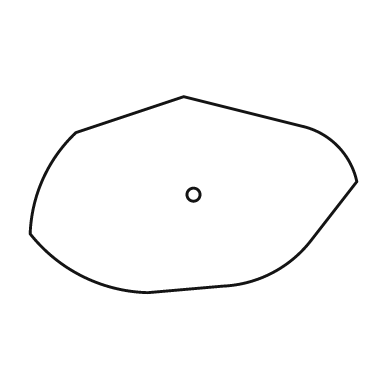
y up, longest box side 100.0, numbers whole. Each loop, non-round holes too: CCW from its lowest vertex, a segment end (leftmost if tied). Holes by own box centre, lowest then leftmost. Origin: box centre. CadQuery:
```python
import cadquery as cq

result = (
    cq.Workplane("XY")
    .moveTo(-14.0, -30.0)
    .lineTo(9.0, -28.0)
    .threePointArc((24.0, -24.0), (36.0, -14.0))
    .lineTo(50.0, 4.0)
    .threePointArc((44.0, 15.0), (33.0, 21.0))
    .lineTo(-3.0, 30.0)
    .lineTo(-36.0, 19.0)
    .threePointArc((-46.0, 5.0), (-50.0, -12.0))
    .threePointArc((-34.0, -25.0), (-14.0, -30.0))
    .close()
    .moveTo(0.0, 0.0)
    .circle(2.0)
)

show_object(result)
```